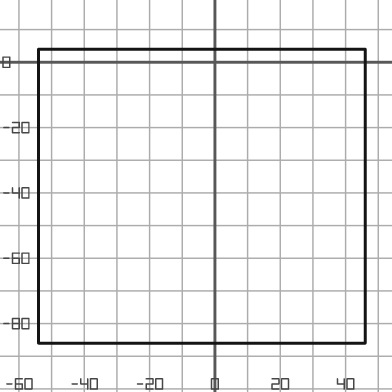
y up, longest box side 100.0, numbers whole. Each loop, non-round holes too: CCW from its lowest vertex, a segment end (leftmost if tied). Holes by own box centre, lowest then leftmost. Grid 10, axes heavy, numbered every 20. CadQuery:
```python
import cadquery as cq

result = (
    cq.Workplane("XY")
    .moveTo(-54.0, -86.0)
    .lineTo(46.0, -86.0)
    .lineTo(46.0, 4.0)
    .lineTo(-54.0, 4.0)
    .close()
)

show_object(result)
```